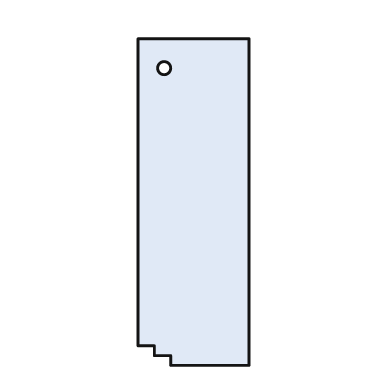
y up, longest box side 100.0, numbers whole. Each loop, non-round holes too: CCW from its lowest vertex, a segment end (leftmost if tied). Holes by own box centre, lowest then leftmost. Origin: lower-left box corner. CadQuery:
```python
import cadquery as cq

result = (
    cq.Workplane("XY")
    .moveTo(10.0, 0.0)
    .lineTo(34.0, 0.0)
    .lineTo(34.0, 100.0)
    .lineTo(0.0, 100.0)
    .lineTo(0.0, 6.0)
    .lineTo(5.0, 6.0)
    .lineTo(5.0, 3.0)
    .lineTo(10.0, 3.0)
    .close()
    .moveTo(8.0, 91.0)
    .circle(2.0)
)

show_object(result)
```